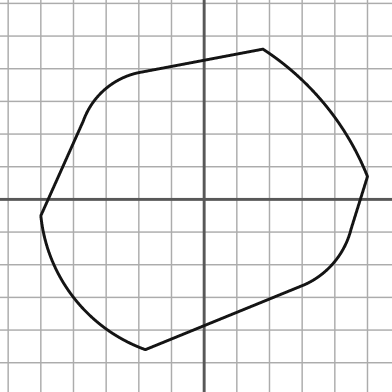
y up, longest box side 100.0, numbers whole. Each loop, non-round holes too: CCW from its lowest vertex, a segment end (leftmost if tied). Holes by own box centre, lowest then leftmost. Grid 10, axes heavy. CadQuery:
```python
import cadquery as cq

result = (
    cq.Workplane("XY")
    .moveTo(-18.0, -46.0)
    .lineTo(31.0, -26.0)
    .threePointArc((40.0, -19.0), (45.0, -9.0))
    .lineTo(50.0, 7.0)
    .threePointArc((37.0, 29.0), (18.0, 46.0))
    .lineTo(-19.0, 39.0)
    .threePointArc((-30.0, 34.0), (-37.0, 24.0))
    .lineTo(-50.0, -5.0)
    .threePointArc((-40.0, -30.0), (-18.0, -46.0))
    .close()
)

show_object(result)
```